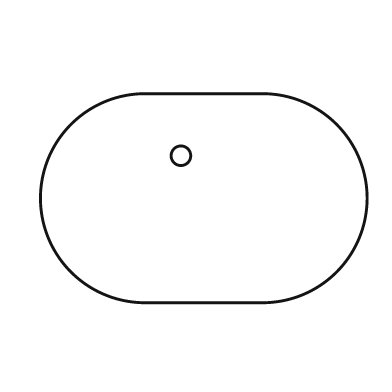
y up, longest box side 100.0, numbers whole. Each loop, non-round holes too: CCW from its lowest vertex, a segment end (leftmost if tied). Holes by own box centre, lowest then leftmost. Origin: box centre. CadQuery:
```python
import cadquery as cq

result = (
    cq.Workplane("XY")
    .moveTo(-18.0, -32.0)
    .lineTo(18.0, -32.0)
    .threePointArc((50.0, 0.0), (18.0, 32.0))
    .lineTo(-18.0, 32.0)
    .threePointArc((-50.0, 0.0), (-18.0, -32.0))
    .close()
    .moveTo(-7.0, 13.0)
    .circle(3.0)
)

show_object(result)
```